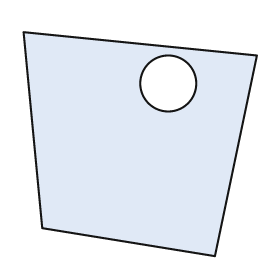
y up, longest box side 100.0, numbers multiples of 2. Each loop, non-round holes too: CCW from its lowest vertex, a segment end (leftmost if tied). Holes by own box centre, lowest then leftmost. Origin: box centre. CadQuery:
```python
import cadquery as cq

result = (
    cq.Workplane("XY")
    .moveTo(32.0, -48.0)
    .lineTo(50.0, 38.0)
    .lineTo(-50.0, 48.0)
    .lineTo(-42.0, -36.0)
    .close()
    .moveTo(12.0, 26.0)
    .circle(12.0)
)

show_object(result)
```